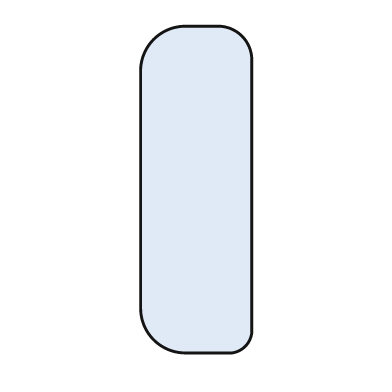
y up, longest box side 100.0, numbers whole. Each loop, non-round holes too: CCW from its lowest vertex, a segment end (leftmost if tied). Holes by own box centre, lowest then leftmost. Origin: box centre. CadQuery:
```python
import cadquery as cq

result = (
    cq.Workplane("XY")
    .moveTo(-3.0, -50.0)
    .lineTo(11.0, -50.0)
    .threePointArc((15.0, -48.0), (17.0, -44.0))
    .lineTo(17.0, 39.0)
    .threePointArc((14.0, 47.0), (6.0, 50.0))
    .lineTo(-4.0, 50.0)
    .threePointArc((-13.0, 46.0), (-17.0, 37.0))
    .lineTo(-17.0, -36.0)
    .threePointArc((-13.0, -46.0), (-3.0, -50.0))
    .close()
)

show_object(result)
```